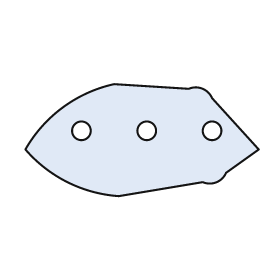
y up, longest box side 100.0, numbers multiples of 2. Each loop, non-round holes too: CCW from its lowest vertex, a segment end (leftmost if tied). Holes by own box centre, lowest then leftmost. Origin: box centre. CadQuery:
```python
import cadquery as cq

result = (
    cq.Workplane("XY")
    .moveTo(-10.0, -24.0)
    .lineTo(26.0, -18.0)
    .threePointArc((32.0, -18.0), (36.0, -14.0))
    .lineTo(50.0, -4.0)
    .lineTo(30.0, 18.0)
    .threePointArc((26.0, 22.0), (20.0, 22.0))
    .lineTo(-12.0, 24.0)
    .threePointArc((-34.0, 14.0), (-50.0, -4.0))
    .threePointArc((-32.0, -18.0), (-10.0, -24.0))
    .close()
    .moveTo(-26.0, 4.0)
    .circle(4.0)
    .moveTo(2.0, 4.0)
    .circle(4.0)
    .moveTo(30.0, 4.0)
    .circle(4.0)
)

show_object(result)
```